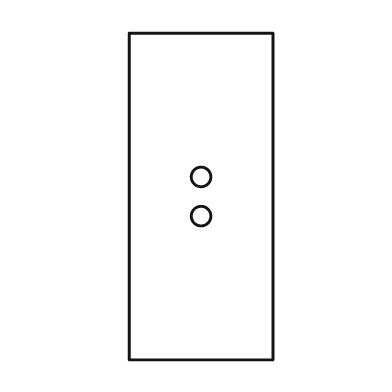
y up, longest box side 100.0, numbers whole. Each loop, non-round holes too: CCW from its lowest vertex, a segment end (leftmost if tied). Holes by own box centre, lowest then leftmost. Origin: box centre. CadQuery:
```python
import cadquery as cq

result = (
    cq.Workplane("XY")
    .moveTo(-22.0, -50.0)
    .lineTo(22.0, -50.0)
    .lineTo(22.0, 50.0)
    .lineTo(-22.0, 50.0)
    .close()
    .moveTo(0.0, -6.0)
    .circle(3.0)
    .moveTo(0.0, 6.0)
    .circle(3.0)
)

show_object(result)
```